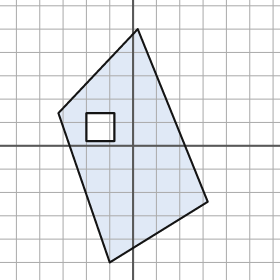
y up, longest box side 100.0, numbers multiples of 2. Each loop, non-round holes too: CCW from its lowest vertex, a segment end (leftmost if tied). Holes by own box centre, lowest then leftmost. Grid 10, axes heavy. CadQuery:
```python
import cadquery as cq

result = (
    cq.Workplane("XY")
    .moveTo(-10.0, -50.0)
    .lineTo(32.0, -24.0)
    .lineTo(2.0, 50.0)
    .lineTo(-32.0, 14.0)
    .close()
    .moveTo(-20.0, 2.0)
    .lineTo(-8.0, 2.0)
    .lineTo(-8.0, 14.0)
    .lineTo(-20.0, 14.0)
    .close()
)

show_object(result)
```